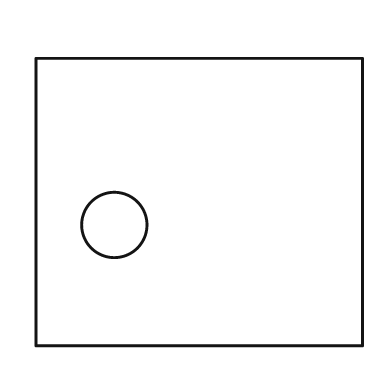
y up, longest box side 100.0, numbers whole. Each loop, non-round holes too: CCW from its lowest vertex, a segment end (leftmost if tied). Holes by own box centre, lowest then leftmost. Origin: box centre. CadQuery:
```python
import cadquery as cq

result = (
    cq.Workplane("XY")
    .moveTo(-50.0, -44.0)
    .lineTo(50.0, -44.0)
    .lineTo(50.0, 44.0)
    .lineTo(-50.0, 44.0)
    .close()
    .moveTo(-26.0, -7.0)
    .circle(10.0)
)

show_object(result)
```